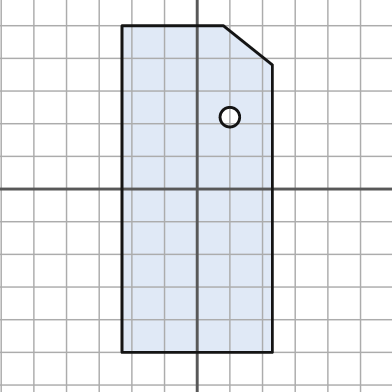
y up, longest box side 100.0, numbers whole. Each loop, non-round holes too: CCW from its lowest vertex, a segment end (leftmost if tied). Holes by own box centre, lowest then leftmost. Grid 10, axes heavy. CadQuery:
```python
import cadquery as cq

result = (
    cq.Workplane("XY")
    .moveTo(-23.0, -50.0)
    .lineTo(23.0, -50.0)
    .lineTo(23.0, 38.0)
    .lineTo(8.0, 50.0)
    .lineTo(-23.0, 50.0)
    .close()
    .moveTo(10.0, 22.0)
    .circle(3.0)
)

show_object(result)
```